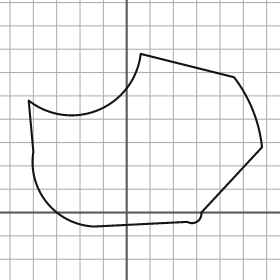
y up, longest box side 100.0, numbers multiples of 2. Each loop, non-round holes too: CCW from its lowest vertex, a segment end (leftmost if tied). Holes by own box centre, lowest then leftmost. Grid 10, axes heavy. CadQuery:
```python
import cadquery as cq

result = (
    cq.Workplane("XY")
    .moveTo(-14.0, -6.0)
    .lineTo(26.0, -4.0)
    .threePointArc((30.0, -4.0), (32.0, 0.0))
    .lineTo(58.0, 28.0)
    .threePointArc((54.0, 44.0), (46.0, 58.0))
    .lineTo(6.0, 68.0)
    .threePointArc((-12.0, 44.0), (-42.0, 48.0))
    .lineTo(-40.0, 26.0)
    .threePointArc((-34.0, 4.0), (-14.0, -6.0))
    .close()
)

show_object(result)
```